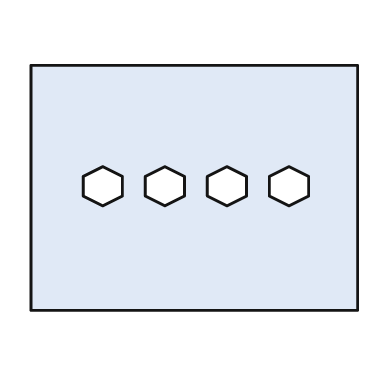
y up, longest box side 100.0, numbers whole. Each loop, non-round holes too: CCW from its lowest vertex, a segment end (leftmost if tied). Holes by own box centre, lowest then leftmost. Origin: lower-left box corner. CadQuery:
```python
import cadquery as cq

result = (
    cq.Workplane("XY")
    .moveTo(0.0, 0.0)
    .lineTo(100.0, 0.0)
    .lineTo(100.0, 75.0)
    .lineTo(0.0, 75.0)
    .close()
    .moveTo(22.0, 32.0)
    .lineTo(28.0, 35.0)
    .lineTo(28.0, 41.0)
    .lineTo(22.0, 44.0)
    .lineTo(16.0, 41.0)
    .lineTo(16.0, 35.0)
    .close()
    .moveTo(41.0, 32.0)
    .lineTo(47.0, 35.0)
    .lineTo(47.0, 41.0)
    .lineTo(41.0, 44.0)
    .lineTo(35.0, 41.0)
    .lineTo(35.0, 35.0)
    .close()
    .moveTo(60.0, 32.0)
    .lineTo(66.0, 35.0)
    .lineTo(66.0, 41.0)
    .lineTo(60.0, 44.0)
    .lineTo(54.0, 41.0)
    .lineTo(54.0, 35.0)
    .close()
    .moveTo(79.0, 32.0)
    .lineTo(85.0, 35.0)
    .lineTo(85.0, 41.0)
    .lineTo(79.0, 44.0)
    .lineTo(73.0, 41.0)
    .lineTo(73.0, 35.0)
    .close()
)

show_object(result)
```